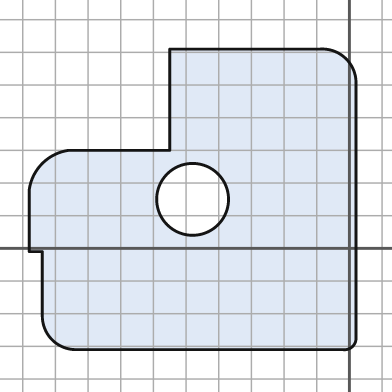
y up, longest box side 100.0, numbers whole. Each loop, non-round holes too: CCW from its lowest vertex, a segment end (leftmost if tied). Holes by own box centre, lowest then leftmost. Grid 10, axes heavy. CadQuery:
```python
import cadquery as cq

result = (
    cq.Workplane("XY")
    .moveTo(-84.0, -31.0)
    .lineTo(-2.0, -31.0)
    .threePointArc((1.0, -30.0), (2.0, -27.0))
    .lineTo(2.0, 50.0)
    .threePointArc((-1.0, 58.0), (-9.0, 61.0))
    .lineTo(-55.0, 61.0)
    .lineTo(-55.0, 30.0)
    .lineTo(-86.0, 30.0)
    .threePointArc((-94.0, 26.0), (-98.0, 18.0))
    .lineTo(-98.0, -1.0)
    .lineTo(-94.0, -1.0)
    .lineTo(-94.0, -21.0)
    .threePointArc((-91.0, -28.0), (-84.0, -31.0))
    .close()
    .moveTo(-48.0, 15.0)
    .circle(11.0)
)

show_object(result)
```